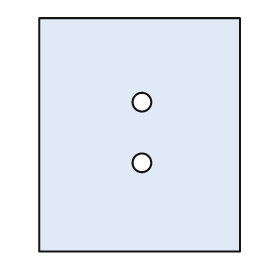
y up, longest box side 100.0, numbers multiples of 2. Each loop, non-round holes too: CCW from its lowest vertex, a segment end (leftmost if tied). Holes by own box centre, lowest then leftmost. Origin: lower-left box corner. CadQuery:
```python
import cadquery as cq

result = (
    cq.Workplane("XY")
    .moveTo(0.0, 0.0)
    .lineTo(86.0, 0.0)
    .lineTo(86.0, 100.0)
    .lineTo(0.0, 100.0)
    .close()
    .moveTo(44.0, 38.0)
    .circle(4.0)
    .moveTo(44.0, 64.0)
    .circle(4.0)
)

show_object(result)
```